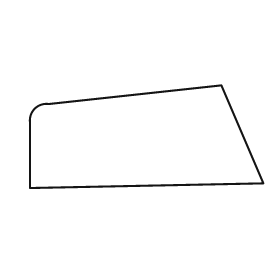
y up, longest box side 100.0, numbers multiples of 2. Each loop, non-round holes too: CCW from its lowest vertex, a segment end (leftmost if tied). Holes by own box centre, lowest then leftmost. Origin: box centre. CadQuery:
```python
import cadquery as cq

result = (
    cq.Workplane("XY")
    .moveTo(-50.0, -22.0)
    .lineTo(50.0, -20.0)
    .lineTo(32.0, 22.0)
    .lineTo(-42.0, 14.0)
    .threePointArc((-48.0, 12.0), (-50.0, 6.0))
    .close()
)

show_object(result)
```